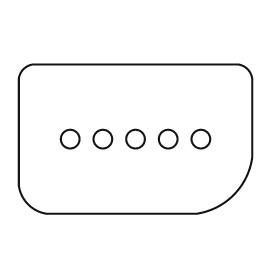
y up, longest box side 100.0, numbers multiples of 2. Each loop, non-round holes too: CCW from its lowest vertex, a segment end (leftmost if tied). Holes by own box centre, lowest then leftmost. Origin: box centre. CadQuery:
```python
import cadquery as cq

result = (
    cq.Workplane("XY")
    .moveTo(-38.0, -32.0)
    .lineTo(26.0, -32.0)
    .threePointArc((42.0, -24.0), (50.0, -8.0))
    .lineTo(50.0, 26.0)
    .threePointArc((48.0, 30.0), (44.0, 32.0))
    .lineTo(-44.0, 32.0)
    .threePointArc((-48.0, 30.0), (-50.0, 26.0))
    .lineTo(-50.0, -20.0)
    .threePointArc((-46.0, -28.0), (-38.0, -32.0))
    .close()
    .moveTo(-28.0, 0.0)
    .circle(4.0)
    .moveTo(-14.0, 0.0)
    .circle(4.0)
    .moveTo(0.0, 0.0)
    .circle(4.0)
    .moveTo(14.0, 0.0)
    .circle(4.0)
    .moveTo(28.0, 0.0)
    .circle(4.0)
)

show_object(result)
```